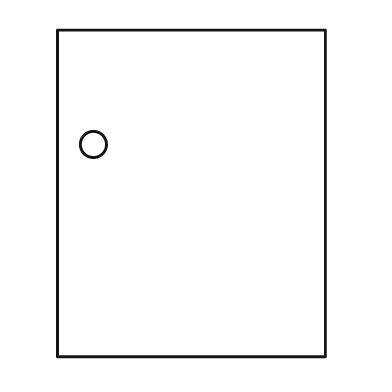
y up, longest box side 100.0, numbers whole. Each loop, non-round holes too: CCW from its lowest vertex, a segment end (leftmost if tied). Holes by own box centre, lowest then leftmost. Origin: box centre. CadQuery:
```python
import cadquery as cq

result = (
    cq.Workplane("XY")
    .moveTo(-41.0, -50.0)
    .lineTo(41.0, -50.0)
    .lineTo(41.0, 50.0)
    .lineTo(-41.0, 50.0)
    .close()
    .moveTo(-30.0, 15.0)
    .circle(4.0)
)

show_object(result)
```